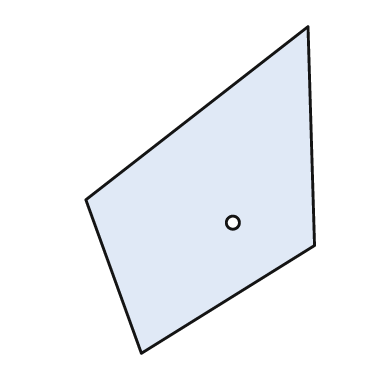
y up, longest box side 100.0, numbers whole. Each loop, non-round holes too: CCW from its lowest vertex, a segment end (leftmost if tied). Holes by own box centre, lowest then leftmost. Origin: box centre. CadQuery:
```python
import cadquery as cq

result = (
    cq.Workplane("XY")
    .moveTo(-18.0, -50.0)
    .lineTo(35.0, -17.0)
    .lineTo(33.0, 50.0)
    .lineTo(-35.0, -3.0)
    .close()
    .moveTo(10.0, -10.0)
    .circle(2.0)
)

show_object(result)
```